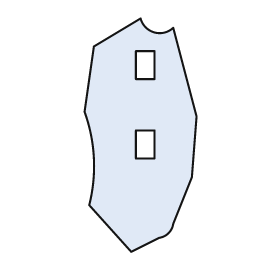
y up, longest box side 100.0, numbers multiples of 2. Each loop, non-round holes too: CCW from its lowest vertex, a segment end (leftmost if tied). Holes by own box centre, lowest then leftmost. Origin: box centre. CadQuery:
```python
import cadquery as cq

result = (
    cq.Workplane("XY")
    .moveTo(-4.0, -50.0)
    .lineTo(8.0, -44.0)
    .threePointArc((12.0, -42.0), (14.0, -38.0))
    .lineTo(22.0, -18.0)
    .lineTo(24.0, 8.0)
    .lineTo(14.0, 46.0)
    .threePointArc((6.0, 44.0), (0.0, 50.0))
    .lineTo(-20.0, 38.0)
    .lineTo(-24.0, 10.0)
    .threePointArc((-20.0, -10.0), (-22.0, -30.0))
    .close()
    .moveTo(-2.0, -10.0)
    .lineTo(6.0, -10.0)
    .lineTo(6.0, 2.0)
    .lineTo(-2.0, 2.0)
    .close()
    .moveTo(-2.0, 24.0)
    .lineTo(6.0, 24.0)
    .lineTo(6.0, 36.0)
    .lineTo(-2.0, 36.0)
    .close()
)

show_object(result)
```